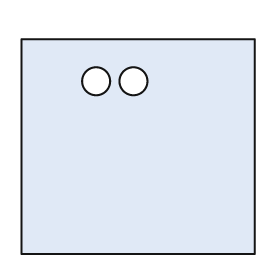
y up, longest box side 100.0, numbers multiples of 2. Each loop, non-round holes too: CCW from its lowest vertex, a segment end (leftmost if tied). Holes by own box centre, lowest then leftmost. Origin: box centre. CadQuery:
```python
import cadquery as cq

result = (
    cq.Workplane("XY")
    .moveTo(-50.0, -46.0)
    .lineTo(50.0, -46.0)
    .lineTo(50.0, 46.0)
    .lineTo(-50.0, 46.0)
    .close()
    .moveTo(-18.0, 28.0)
    .circle(6.0)
    .moveTo(-2.0, 28.0)
    .circle(6.0)
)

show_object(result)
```